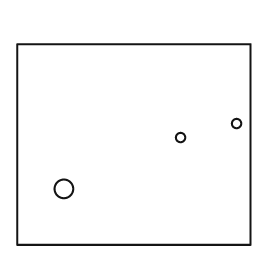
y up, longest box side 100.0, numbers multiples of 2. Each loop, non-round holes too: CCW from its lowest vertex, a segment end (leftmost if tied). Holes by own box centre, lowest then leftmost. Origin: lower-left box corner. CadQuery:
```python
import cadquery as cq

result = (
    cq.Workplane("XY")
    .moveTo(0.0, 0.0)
    .lineTo(100.0, 0.0)
    .lineTo(100.0, 86.0)
    .lineTo(0.0, 86.0)
    .close()
    .moveTo(20.0, 24.0)
    .circle(4.0)
    .moveTo(70.0, 46.0)
    .circle(2.0)
    .moveTo(94.0, 52.0)
    .circle(2.0)
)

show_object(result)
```